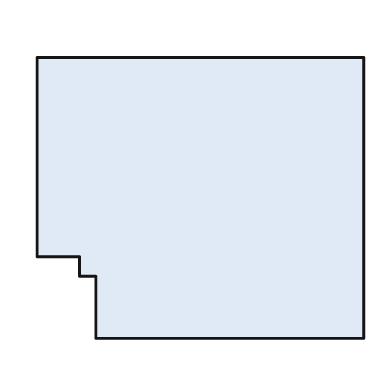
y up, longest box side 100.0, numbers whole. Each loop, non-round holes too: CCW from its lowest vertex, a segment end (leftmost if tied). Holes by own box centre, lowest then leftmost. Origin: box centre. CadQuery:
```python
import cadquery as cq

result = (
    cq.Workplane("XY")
    .moveTo(-32.0, -43.0)
    .lineTo(50.0, -43.0)
    .lineTo(50.0, 43.0)
    .lineTo(-50.0, 43.0)
    .lineTo(-50.0, -18.0)
    .lineTo(-37.0, -18.0)
    .lineTo(-37.0, -24.0)
    .lineTo(-32.0, -24.0)
    .close()
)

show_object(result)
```